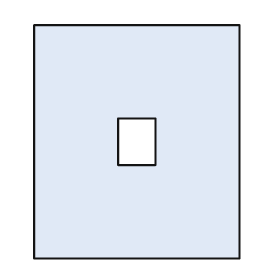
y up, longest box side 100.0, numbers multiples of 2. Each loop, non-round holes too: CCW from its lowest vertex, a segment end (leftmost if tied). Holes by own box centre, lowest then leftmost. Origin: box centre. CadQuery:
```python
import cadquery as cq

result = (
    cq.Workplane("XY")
    .moveTo(-44.0, -50.0)
    .lineTo(44.0, -50.0)
    .lineTo(44.0, 50.0)
    .lineTo(-44.0, 50.0)
    .close()
    .moveTo(-8.0, -10.0)
    .lineTo(8.0, -10.0)
    .lineTo(8.0, 10.0)
    .lineTo(-8.0, 10.0)
    .close()
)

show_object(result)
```